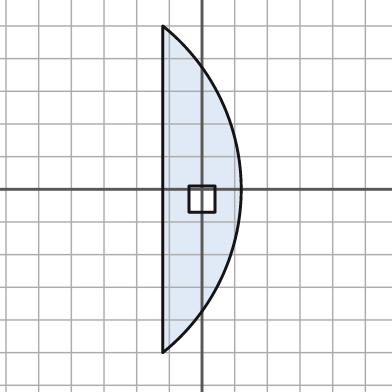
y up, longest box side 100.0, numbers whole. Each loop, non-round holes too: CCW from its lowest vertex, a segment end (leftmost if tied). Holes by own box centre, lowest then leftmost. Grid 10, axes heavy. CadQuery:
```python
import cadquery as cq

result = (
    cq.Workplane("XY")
    .moveTo(-12.0, -50.0)
    .threePointArc((12.0, 0.0), (-12.0, 50.0))
    .close()
    .moveTo(-4.0, -7.0)
    .lineTo(4.0, -7.0)
    .lineTo(4.0, 1.0)
    .lineTo(-4.0, 1.0)
    .close()
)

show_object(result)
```